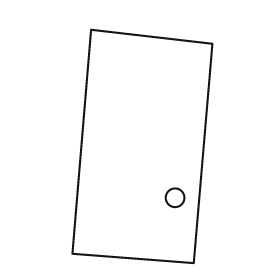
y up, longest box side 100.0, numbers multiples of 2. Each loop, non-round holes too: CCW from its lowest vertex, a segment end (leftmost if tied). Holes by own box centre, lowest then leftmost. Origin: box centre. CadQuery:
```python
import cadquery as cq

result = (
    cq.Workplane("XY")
    .moveTo(22.0, -50.0)
    .lineTo(30.0, 44.0)
    .lineTo(-22.0, 50.0)
    .lineTo(-30.0, -46.0)
    .close()
    .moveTo(14.0, -22.0)
    .circle(4.0)
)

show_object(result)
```